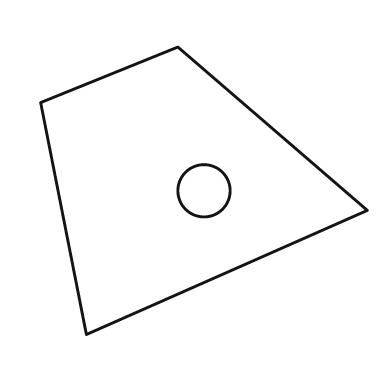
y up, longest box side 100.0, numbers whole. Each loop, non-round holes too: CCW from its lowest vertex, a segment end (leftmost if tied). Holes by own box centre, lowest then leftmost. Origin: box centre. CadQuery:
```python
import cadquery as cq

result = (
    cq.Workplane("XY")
    .moveTo(-36.0, -44.0)
    .lineTo(50.0, -6.0)
    .lineTo(-8.0, 44.0)
    .lineTo(-50.0, 27.0)
    .close()
    .moveTo(0.0, 0.0)
    .circle(8.0)
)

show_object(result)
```